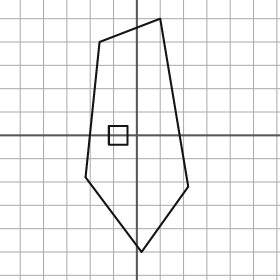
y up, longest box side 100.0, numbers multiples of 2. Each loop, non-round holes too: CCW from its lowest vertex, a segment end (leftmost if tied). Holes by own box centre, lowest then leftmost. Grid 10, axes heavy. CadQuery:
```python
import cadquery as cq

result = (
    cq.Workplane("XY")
    .moveTo(2.0, -50.0)
    .lineTo(22.0, -22.0)
    .lineTo(10.0, 50.0)
    .lineTo(-16.0, 40.0)
    .lineTo(-22.0, -18.0)
    .close()
    .moveTo(-12.0, -4.0)
    .lineTo(-4.0, -4.0)
    .lineTo(-4.0, 4.0)
    .lineTo(-12.0, 4.0)
    .close()
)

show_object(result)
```